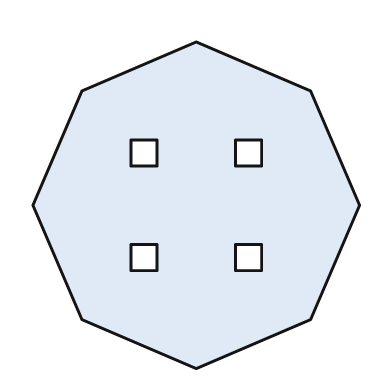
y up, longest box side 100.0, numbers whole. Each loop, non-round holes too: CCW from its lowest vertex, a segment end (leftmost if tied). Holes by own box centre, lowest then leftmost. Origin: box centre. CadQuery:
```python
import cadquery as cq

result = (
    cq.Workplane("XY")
    .moveTo(0.0, -50.0)
    .lineTo(35.0, -35.0)
    .lineTo(50.0, 0.0)
    .lineTo(35.0, 35.0)
    .lineTo(0.0, 50.0)
    .lineTo(-35.0, 35.0)
    .lineTo(-50.0, 0.0)
    .lineTo(-35.0, -35.0)
    .close()
    .moveTo(-20.0, -20.0)
    .lineTo(-12.0, -20.0)
    .lineTo(-12.0, -12.0)
    .lineTo(-20.0, -12.0)
    .close()
    .moveTo(12.0, -20.0)
    .lineTo(20.0, -20.0)
    .lineTo(20.0, -12.0)
    .lineTo(12.0, -12.0)
    .close()
    .moveTo(-20.0, 12.0)
    .lineTo(-12.0, 12.0)
    .lineTo(-12.0, 20.0)
    .lineTo(-20.0, 20.0)
    .close()
    .moveTo(12.0, 12.0)
    .lineTo(20.0, 12.0)
    .lineTo(20.0, 20.0)
    .lineTo(12.0, 20.0)
    .close()
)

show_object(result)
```